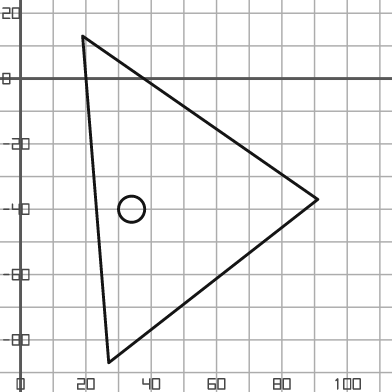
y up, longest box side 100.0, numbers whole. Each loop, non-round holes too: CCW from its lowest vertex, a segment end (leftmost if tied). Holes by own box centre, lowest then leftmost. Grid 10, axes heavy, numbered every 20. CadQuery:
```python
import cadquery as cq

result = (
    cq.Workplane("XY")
    .moveTo(27.0, -87.0)
    .lineTo(91.0, -37.0)
    .lineTo(19.0, 13.0)
    .close()
    .moveTo(34.0, -40.0)
    .circle(4.0)
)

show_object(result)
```